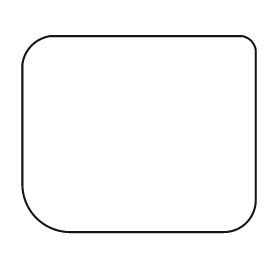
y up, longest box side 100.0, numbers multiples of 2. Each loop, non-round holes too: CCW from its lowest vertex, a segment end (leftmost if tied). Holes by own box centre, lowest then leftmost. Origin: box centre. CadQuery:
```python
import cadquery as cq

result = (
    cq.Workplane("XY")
    .moveTo(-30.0, -42.0)
    .lineTo(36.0, -42.0)
    .threePointArc((46.0, -38.0), (50.0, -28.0))
    .lineTo(50.0, 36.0)
    .threePointArc((48.0, 40.0), (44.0, 42.0))
    .lineTo(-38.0, 42.0)
    .threePointArc((-46.0, 38.0), (-50.0, 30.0))
    .lineTo(-50.0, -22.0)
    .threePointArc((-44.0, -36.0), (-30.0, -42.0))
    .close()
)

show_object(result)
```